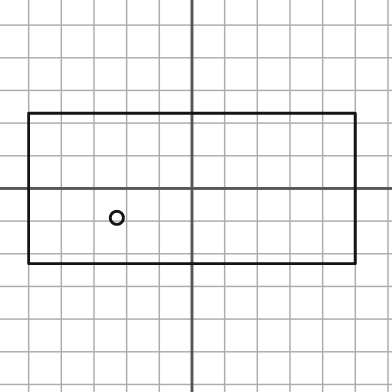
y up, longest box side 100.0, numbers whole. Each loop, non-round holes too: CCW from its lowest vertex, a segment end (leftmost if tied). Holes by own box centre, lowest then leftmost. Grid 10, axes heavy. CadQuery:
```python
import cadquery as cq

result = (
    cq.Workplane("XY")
    .moveTo(-50.0, -23.0)
    .lineTo(50.0, -23.0)
    .lineTo(50.0, 23.0)
    .lineTo(-50.0, 23.0)
    .close()
    .moveTo(-23.0, -9.0)
    .circle(2.0)
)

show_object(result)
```